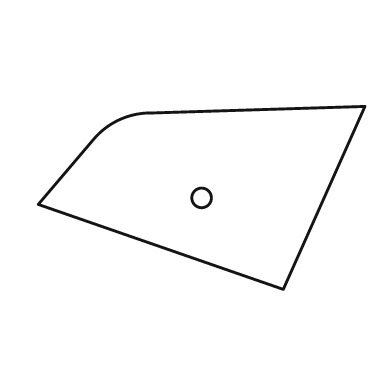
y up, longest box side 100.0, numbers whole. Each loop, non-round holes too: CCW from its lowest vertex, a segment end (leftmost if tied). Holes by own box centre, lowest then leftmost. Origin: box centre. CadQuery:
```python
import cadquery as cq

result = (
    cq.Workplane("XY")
    .moveTo(25.0, -28.0)
    .lineTo(50.0, 28.0)
    .lineTo(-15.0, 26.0)
    .threePointArc((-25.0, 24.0), (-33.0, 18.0))
    .lineTo(-50.0, -2.0)
    .close()
    .moveTo(0.0, 0.0)
    .circle(3.0)
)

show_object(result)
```